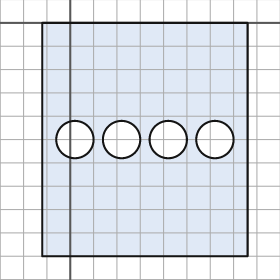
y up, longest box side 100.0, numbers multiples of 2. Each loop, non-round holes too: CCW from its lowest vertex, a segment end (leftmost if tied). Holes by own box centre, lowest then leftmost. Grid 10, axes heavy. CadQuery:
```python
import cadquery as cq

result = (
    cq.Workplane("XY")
    .moveTo(-12.0, -100.0)
    .lineTo(76.0, -100.0)
    .lineTo(76.0, 0.0)
    .lineTo(-12.0, 0.0)
    .close()
    .moveTo(2.0, -50.0)
    .circle(8.0)
    .moveTo(22.0, -50.0)
    .circle(8.0)
    .moveTo(42.0, -50.0)
    .circle(8.0)
    .moveTo(62.0, -50.0)
    .circle(8.0)
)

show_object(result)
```